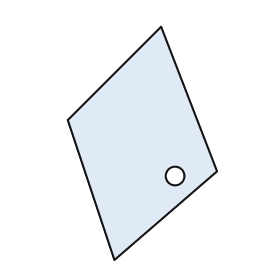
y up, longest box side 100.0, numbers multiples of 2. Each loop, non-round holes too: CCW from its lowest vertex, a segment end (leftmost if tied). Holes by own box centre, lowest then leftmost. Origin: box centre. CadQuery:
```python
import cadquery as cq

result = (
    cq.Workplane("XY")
    .moveTo(-12.0, -50.0)
    .lineTo(32.0, -12.0)
    .lineTo(8.0, 50.0)
    .lineTo(-32.0, 10.0)
    .close()
    .moveTo(14.0, -14.0)
    .circle(4.0)
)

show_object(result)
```